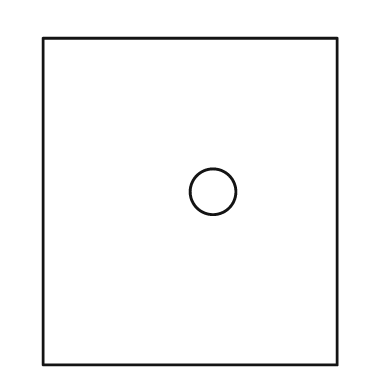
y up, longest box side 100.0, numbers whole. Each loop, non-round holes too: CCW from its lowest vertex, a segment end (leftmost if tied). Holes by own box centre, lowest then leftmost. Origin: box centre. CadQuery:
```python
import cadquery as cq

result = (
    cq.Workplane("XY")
    .moveTo(-45.0, -50.0)
    .lineTo(45.0, -50.0)
    .lineTo(45.0, 50.0)
    .lineTo(-45.0, 50.0)
    .close()
    .moveTo(7.0, 3.0)
    .circle(7.0)
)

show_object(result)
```